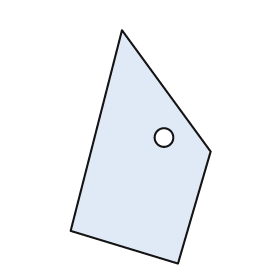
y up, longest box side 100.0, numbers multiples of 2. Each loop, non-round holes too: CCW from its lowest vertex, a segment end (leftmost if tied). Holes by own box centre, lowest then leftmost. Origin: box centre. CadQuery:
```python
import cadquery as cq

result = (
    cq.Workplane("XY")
    .moveTo(16.0, -50.0)
    .lineTo(30.0, -2.0)
    .lineTo(-8.0, 50.0)
    .lineTo(-30.0, -36.0)
    .close()
    .moveTo(10.0, 4.0)
    .circle(4.0)
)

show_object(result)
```